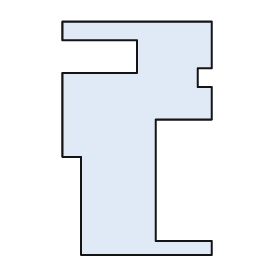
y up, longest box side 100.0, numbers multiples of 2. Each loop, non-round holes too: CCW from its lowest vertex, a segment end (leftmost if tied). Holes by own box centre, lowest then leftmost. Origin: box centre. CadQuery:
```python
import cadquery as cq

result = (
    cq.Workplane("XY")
    .moveTo(-24.0, -50.0)
    .lineTo(32.0, -50.0)
    .lineTo(32.0, -44.0)
    .lineTo(8.0, -44.0)
    .lineTo(8.0, 8.0)
    .lineTo(32.0, 8.0)
    .lineTo(32.0, 22.0)
    .lineTo(26.0, 22.0)
    .lineTo(26.0, 30.0)
    .lineTo(32.0, 30.0)
    .lineTo(32.0, 50.0)
    .lineTo(-32.0, 50.0)
    .lineTo(-32.0, 42.0)
    .lineTo(0.0, 42.0)
    .lineTo(0.0, 28.0)
    .lineTo(-32.0, 28.0)
    .lineTo(-32.0, -8.0)
    .lineTo(-24.0, -8.0)
    .close()
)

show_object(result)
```